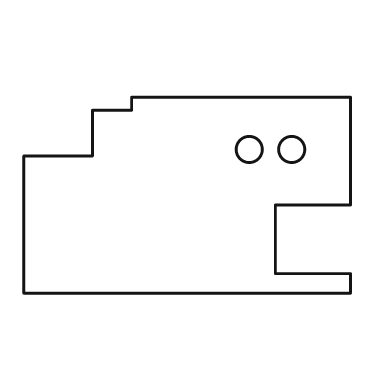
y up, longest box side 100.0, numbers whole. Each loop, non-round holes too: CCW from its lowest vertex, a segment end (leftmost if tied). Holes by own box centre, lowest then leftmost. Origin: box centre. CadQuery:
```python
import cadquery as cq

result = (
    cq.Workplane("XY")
    .moveTo(-50.0, -30.0)
    .lineTo(50.0, -30.0)
    .lineTo(50.0, -24.0)
    .lineTo(27.0, -24.0)
    .lineTo(27.0, -3.0)
    .lineTo(50.0, -3.0)
    .lineTo(50.0, 30.0)
    .lineTo(-17.0, 30.0)
    .lineTo(-17.0, 26.0)
    .lineTo(-29.0, 26.0)
    .lineTo(-29.0, 12.0)
    .lineTo(-50.0, 12.0)
    .close()
    .moveTo(19.0, 14.0)
    .circle(4.0)
    .moveTo(32.0, 14.0)
    .circle(4.0)
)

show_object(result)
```